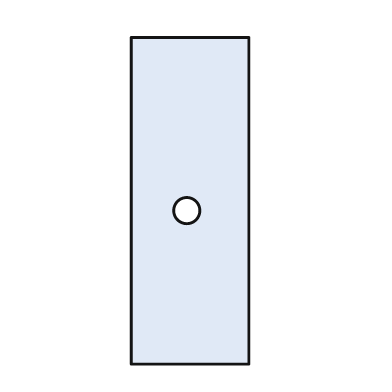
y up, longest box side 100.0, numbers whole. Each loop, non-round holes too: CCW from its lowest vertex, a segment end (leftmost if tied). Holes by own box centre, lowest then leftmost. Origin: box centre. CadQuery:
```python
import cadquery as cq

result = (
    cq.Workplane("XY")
    .moveTo(-18.0, -50.0)
    .lineTo(18.0, -50.0)
    .lineTo(18.0, 50.0)
    .lineTo(-18.0, 50.0)
    .close()
    .moveTo(-1.0, -3.0)
    .circle(4.0)
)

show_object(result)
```